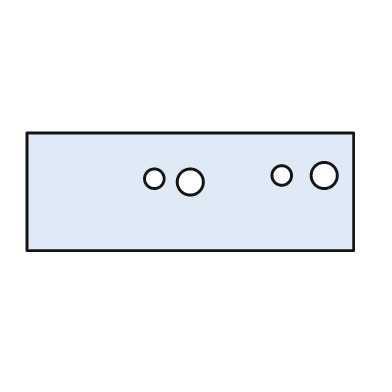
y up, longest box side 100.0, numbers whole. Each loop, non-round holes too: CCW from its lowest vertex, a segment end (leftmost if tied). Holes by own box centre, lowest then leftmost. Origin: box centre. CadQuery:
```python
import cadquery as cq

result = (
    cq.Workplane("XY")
    .moveTo(-50.0, -18.0)
    .lineTo(50.0, -18.0)
    .lineTo(50.0, 18.0)
    .lineTo(-50.0, 18.0)
    .close()
    .moveTo(0.0, 3.0)
    .circle(4.0)
    .moveTo(-11.0, 4.0)
    .circle(3.0)
    .moveTo(28.0, 5.0)
    .circle(3.0)
    .moveTo(41.0, 5.0)
    .circle(4.0)
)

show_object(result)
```